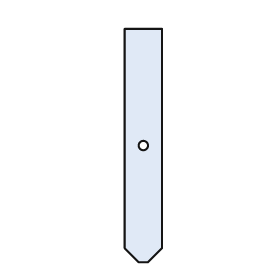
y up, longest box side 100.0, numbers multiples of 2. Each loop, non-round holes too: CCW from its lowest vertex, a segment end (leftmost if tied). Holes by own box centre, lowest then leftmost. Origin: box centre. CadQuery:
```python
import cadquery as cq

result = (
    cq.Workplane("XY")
    .moveTo(-2.0, -50.0)
    .lineTo(2.0, -50.0)
    .lineTo(8.0, -44.0)
    .lineTo(8.0, 50.0)
    .lineTo(-8.0, 50.0)
    .lineTo(-8.0, -44.0)
    .close()
    .moveTo(0.0, 0.0)
    .circle(2.0)
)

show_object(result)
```